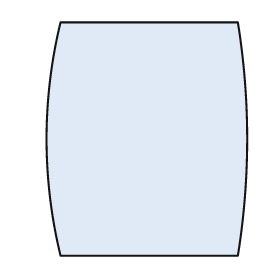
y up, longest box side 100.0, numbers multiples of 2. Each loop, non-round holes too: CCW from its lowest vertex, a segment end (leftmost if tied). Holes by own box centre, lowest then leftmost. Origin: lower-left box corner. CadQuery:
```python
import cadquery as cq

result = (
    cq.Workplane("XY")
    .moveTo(6.0, 0.0)
    .lineTo(82.0, 0.0)
    .threePointArc((86.0, 50.0), (82.0, 100.0))
    .lineTo(6.0, 100.0)
    .threePointArc((0.0, 50.0), (6.0, 0.0))
    .close()
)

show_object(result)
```